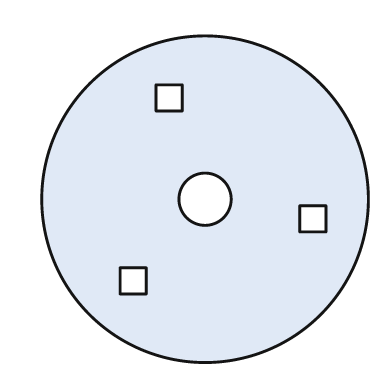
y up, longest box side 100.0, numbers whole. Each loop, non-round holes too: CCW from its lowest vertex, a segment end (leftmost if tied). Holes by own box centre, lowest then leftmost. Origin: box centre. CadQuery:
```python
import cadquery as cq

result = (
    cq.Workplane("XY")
    .moveTo(0.0, 0.0)
    .circle(50.0)
    .moveTo(-26.0, -29.0)
    .lineTo(-18.0, -29.0)
    .lineTo(-18.0, -21.0)
    .lineTo(-26.0, -21.0)
    .close()
    .moveTo(29.0, -10.0)
    .lineTo(37.0, -10.0)
    .lineTo(37.0, -2.0)
    .lineTo(29.0, -2.0)
    .close()
    .moveTo(0.0, 0.0)
    .circle(8.0)
    .moveTo(-15.0, 27.0)
    .lineTo(-7.0, 27.0)
    .lineTo(-7.0, 35.0)
    .lineTo(-15.0, 35.0)
    .close()
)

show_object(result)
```